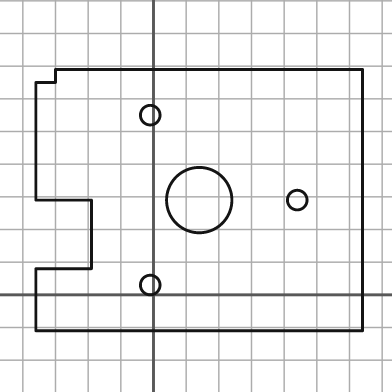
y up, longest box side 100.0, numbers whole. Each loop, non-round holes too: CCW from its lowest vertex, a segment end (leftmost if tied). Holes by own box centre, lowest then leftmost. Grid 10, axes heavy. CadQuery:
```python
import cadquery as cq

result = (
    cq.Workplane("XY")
    .moveTo(-36.0, -11.0)
    .lineTo(64.0, -11.0)
    .lineTo(64.0, 69.0)
    .lineTo(-30.0, 69.0)
    .lineTo(-30.0, 65.0)
    .lineTo(-36.0, 65.0)
    .lineTo(-36.0, 29.0)
    .lineTo(-19.0, 29.0)
    .lineTo(-19.0, 8.0)
    .lineTo(-36.0, 8.0)
    .close()
    .moveTo(-1.0, 3.0)
    .circle(3.0)
    .moveTo(14.0, 29.0)
    .circle(10.0)
    .moveTo(44.0, 29.0)
    .circle(3.0)
    .moveTo(-1.0, 55.0)
    .circle(3.0)
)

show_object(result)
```